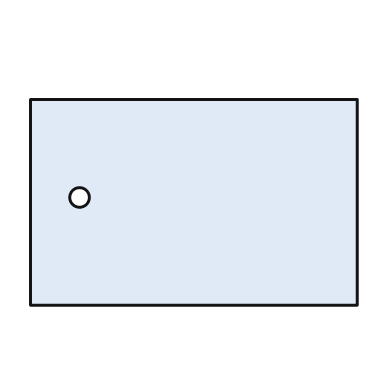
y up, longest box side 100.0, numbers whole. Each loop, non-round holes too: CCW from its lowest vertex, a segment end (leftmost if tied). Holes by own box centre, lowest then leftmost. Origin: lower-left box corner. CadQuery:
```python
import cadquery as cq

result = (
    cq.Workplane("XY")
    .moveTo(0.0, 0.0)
    .lineTo(100.0, 0.0)
    .lineTo(100.0, 63.0)
    .lineTo(0.0, 63.0)
    .close()
    .moveTo(15.0, 33.0)
    .circle(3.0)
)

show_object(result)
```